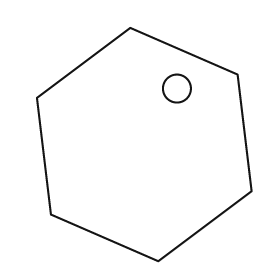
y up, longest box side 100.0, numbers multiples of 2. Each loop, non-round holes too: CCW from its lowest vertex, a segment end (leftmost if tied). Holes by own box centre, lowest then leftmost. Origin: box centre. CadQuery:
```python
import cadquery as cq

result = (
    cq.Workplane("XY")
    .moveTo(6.0, -50.0)
    .lineTo(46.0, -20.0)
    .lineTo(40.0, 30.0)
    .lineTo(-6.0, 50.0)
    .lineTo(-46.0, 20.0)
    .lineTo(-40.0, -30.0)
    .close()
    .moveTo(14.0, 24.0)
    .circle(6.0)
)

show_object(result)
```